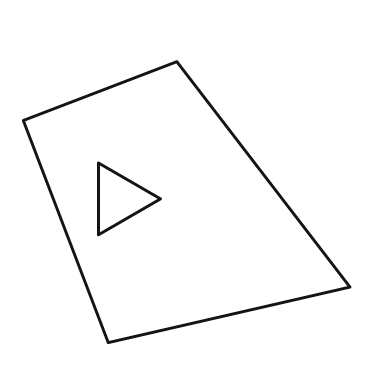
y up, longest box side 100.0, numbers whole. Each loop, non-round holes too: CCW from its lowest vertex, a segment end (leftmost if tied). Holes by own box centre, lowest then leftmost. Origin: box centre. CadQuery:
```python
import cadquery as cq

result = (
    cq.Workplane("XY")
    .moveTo(-24.0, -43.0)
    .lineTo(50.0, -26.0)
    .lineTo(-3.0, 43.0)
    .lineTo(-50.0, 25.0)
    .close()
    .moveTo(-27.0, -10.0)
    .lineTo(-8.0, 1.0)
    .lineTo(-27.0, 12.0)
    .close()
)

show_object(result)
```